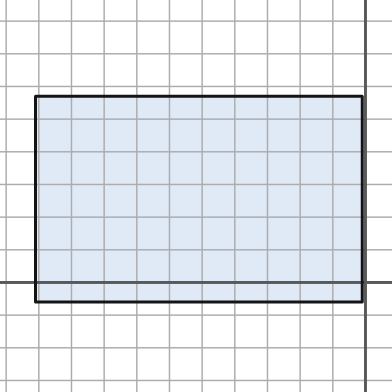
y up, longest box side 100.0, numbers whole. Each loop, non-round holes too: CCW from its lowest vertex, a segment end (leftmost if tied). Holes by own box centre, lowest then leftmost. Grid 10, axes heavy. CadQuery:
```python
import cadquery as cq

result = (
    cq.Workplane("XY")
    .moveTo(-101.0, -6.0)
    .lineTo(-1.0, -6.0)
    .lineTo(-1.0, 57.0)
    .lineTo(-101.0, 57.0)
    .close()
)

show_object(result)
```